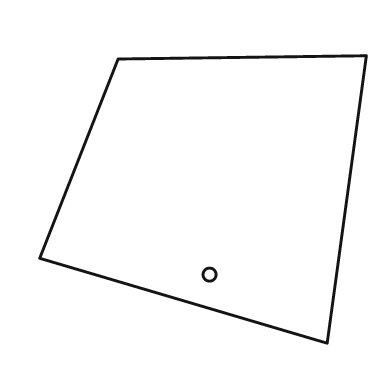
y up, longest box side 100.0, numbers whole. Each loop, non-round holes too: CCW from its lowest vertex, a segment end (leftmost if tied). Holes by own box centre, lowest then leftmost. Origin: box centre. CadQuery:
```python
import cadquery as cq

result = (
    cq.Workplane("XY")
    .moveTo(38.0, -44.0)
    .lineTo(50.0, 44.0)
    .lineTo(-26.0, 43.0)
    .lineTo(-50.0, -18.0)
    .close()
    .moveTo(2.0, -23.0)
    .circle(2.0)
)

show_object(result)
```